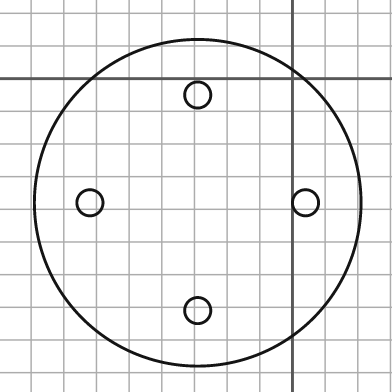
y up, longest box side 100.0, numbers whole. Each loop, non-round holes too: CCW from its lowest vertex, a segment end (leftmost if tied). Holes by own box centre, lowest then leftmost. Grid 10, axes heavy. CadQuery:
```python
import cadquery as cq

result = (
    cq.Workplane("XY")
    .moveTo(-29.0, -38.0)
    .circle(50.0)
    .moveTo(-29.0, -71.0)
    .circle(4.0)
    .moveTo(-62.0, -38.0)
    .circle(4.0)
    .moveTo(4.0, -38.0)
    .circle(4.0)
    .moveTo(-29.0, -5.0)
    .circle(4.0)
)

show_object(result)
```